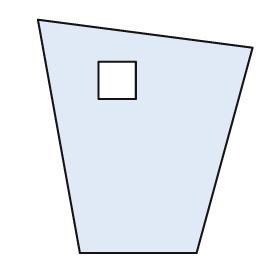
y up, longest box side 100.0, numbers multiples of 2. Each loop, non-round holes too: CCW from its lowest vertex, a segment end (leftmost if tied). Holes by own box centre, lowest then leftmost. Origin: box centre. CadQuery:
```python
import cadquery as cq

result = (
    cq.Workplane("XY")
    .moveTo(-28.0, -50.0)
    .lineTo(22.0, -50.0)
    .lineTo(46.0, 38.0)
    .lineTo(-46.0, 50.0)
    .close()
    .moveTo(-20.0, 16.0)
    .lineTo(-4.0, 16.0)
    .lineTo(-4.0, 32.0)
    .lineTo(-20.0, 32.0)
    .close()
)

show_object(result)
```